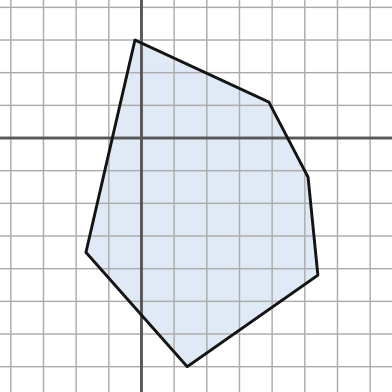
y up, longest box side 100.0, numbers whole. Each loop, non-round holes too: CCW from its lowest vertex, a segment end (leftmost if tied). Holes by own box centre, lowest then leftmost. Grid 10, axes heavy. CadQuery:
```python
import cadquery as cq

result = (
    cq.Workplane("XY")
    .moveTo(14.0, -70.0)
    .lineTo(54.0, -42.0)
    .lineTo(51.0, -12.0)
    .lineTo(39.0, 11.0)
    .lineTo(-2.0, 30.0)
    .lineTo(-17.0, -35.0)
    .close()
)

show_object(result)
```